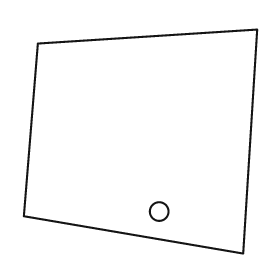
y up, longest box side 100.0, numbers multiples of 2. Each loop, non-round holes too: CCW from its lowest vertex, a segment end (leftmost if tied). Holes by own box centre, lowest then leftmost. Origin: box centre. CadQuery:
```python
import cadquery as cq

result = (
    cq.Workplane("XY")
    .moveTo(44.0, -48.0)
    .lineTo(50.0, 48.0)
    .lineTo(-44.0, 42.0)
    .lineTo(-50.0, -32.0)
    .close()
    .moveTo(8.0, -30.0)
    .circle(4.0)
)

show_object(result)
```